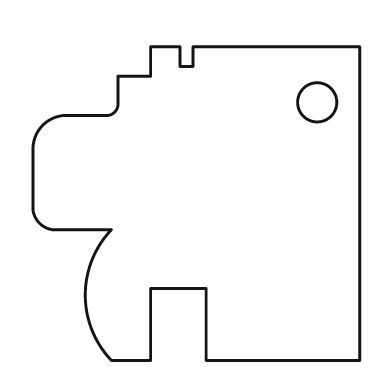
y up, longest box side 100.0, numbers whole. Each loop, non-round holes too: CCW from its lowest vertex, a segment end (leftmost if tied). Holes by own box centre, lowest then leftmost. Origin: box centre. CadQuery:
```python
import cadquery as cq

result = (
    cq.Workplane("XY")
    .moveTo(-26.0, -48.0)
    .lineTo(-14.0, -48.0)
    .lineTo(-14.0, -26.0)
    .lineTo(3.0, -26.0)
    .lineTo(3.0, -48.0)
    .lineTo(50.0, -48.0)
    .lineTo(50.0, 48.0)
    .lineTo(-1.0, 48.0)
    .lineTo(-1.0, 42.0)
    .lineTo(-5.0, 42.0)
    .lineTo(-5.0, 48.0)
    .lineTo(-14.0, 48.0)
    .lineTo(-14.0, 39.0)
    .lineTo(-24.0, 39.0)
    .lineTo(-24.0, 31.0)
    .threePointArc((-25.0, 28.0), (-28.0, 27.0))
    .lineTo(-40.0, 27.0)
    .threePointArc((-47.0, 24.0), (-50.0, 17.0))
    .lineTo(-50.0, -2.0)
    .threePointArc((-48.0, -6.0), (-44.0, -8.0))
    .lineTo(-26.0, -8.0)
    .threePointArc((-34.0, -28.0), (-26.0, -48.0))
    .close()
    .moveTo(37.0, 31.0)
    .circle(6.0)
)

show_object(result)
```